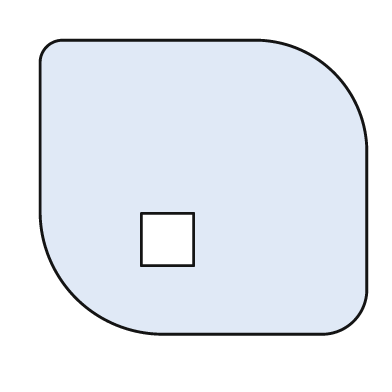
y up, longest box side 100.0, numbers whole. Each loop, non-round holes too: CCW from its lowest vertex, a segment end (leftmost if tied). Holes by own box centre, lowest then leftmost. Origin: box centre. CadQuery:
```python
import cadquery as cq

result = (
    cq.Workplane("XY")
    .moveTo(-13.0, -45.0)
    .lineTo(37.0, -45.0)
    .threePointArc((46.0, -41.0), (50.0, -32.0))
    .lineTo(50.0, 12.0)
    .threePointArc((40.0, 35.0), (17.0, 45.0))
    .lineTo(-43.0, 45.0)
    .threePointArc((-48.0, 43.0), (-50.0, 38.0))
    .lineTo(-50.0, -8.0)
    .threePointArc((-39.0, -34.0), (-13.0, -45.0))
    .close()
    .moveTo(-19.0, -24.0)
    .lineTo(-3.0, -24.0)
    .lineTo(-3.0, -8.0)
    .lineTo(-19.0, -8.0)
    .close()
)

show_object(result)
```